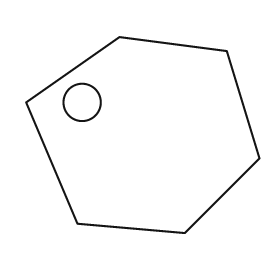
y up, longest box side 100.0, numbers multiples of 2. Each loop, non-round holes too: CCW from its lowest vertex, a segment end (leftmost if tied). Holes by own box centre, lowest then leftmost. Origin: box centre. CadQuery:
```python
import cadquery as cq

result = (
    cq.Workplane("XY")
    .moveTo(18.0, -42.0)
    .lineTo(50.0, -10.0)
    .lineTo(36.0, 36.0)
    .lineTo(-10.0, 42.0)
    .lineTo(-50.0, 14.0)
    .lineTo(-28.0, -38.0)
    .close()
    .moveTo(-26.0, 14.0)
    .circle(8.0)
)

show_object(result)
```